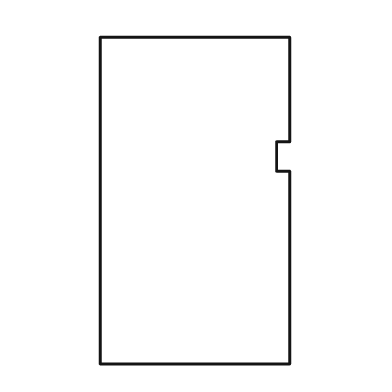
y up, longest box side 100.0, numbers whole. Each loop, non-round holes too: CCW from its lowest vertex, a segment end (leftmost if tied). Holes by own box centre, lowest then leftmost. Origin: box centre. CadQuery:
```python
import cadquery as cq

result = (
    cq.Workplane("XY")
    .moveTo(-29.0, -50.0)
    .lineTo(29.0, -50.0)
    .lineTo(29.0, 9.0)
    .lineTo(25.0, 9.0)
    .lineTo(25.0, 18.0)
    .lineTo(29.0, 18.0)
    .lineTo(29.0, 50.0)
    .lineTo(-29.0, 50.0)
    .close()
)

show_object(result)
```